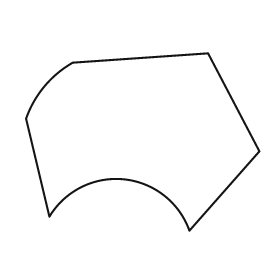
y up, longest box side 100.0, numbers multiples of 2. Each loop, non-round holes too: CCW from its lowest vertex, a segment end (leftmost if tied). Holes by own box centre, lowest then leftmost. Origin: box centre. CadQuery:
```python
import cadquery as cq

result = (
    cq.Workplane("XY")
    .moveTo(20.0, -38.0)
    .lineTo(50.0, -4.0)
    .lineTo(28.0, 38.0)
    .lineTo(-30.0, 34.0)
    .threePointArc((-42.0, 24.0), (-50.0, 10.0))
    .lineTo(-40.0, -32.0)
    .threePointArc((-8.0, -16.0), (20.0, -38.0))
    .close()
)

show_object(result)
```